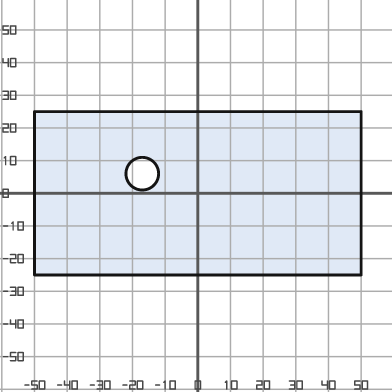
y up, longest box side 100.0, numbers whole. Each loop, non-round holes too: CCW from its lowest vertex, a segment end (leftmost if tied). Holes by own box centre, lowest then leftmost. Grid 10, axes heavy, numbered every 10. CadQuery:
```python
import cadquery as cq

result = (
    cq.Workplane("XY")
    .moveTo(-50.0, -25.0)
    .lineTo(50.0, -25.0)
    .lineTo(50.0, 25.0)
    .lineTo(-50.0, 25.0)
    .close()
    .moveTo(-17.0, 6.0)
    .circle(5.0)
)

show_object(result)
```